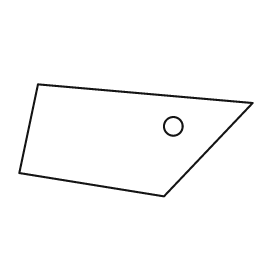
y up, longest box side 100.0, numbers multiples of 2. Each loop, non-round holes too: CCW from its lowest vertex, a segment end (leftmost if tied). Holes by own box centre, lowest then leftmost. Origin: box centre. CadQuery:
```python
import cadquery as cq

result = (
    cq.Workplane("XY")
    .moveTo(12.0, -24.0)
    .lineTo(50.0, 16.0)
    .lineTo(-42.0, 24.0)
    .lineTo(-50.0, -14.0)
    .close()
    .moveTo(16.0, 6.0)
    .circle(4.0)
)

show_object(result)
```